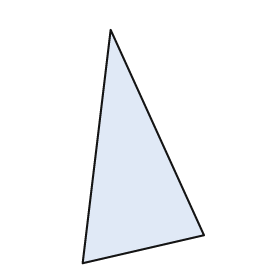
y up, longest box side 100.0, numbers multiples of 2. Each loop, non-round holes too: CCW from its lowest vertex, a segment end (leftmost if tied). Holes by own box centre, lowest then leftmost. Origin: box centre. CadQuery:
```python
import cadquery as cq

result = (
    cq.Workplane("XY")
    .moveTo(-26.0, -50.0)
    .lineTo(26.0, -38.0)
    .lineTo(-14.0, 50.0)
    .close()
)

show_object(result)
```